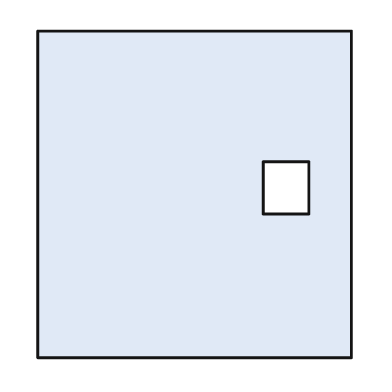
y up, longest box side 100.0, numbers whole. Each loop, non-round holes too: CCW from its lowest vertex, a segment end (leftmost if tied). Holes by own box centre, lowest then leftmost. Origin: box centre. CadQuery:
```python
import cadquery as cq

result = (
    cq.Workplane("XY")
    .moveTo(-48.0, -50.0)
    .lineTo(48.0, -50.0)
    .lineTo(48.0, 50.0)
    .lineTo(-48.0, 50.0)
    .close()
    .moveTo(21.0, -6.0)
    .lineTo(35.0, -6.0)
    .lineTo(35.0, 10.0)
    .lineTo(21.0, 10.0)
    .close()
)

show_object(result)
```